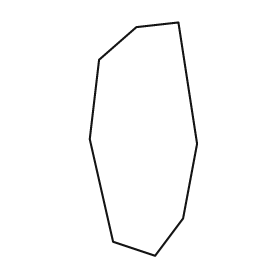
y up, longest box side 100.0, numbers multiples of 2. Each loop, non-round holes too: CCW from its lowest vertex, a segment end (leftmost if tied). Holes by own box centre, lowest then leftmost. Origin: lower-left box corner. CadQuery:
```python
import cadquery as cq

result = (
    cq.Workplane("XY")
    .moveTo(28.0, 0.0)
    .lineTo(40.0, 16.0)
    .lineTo(46.0, 48.0)
    .lineTo(38.0, 100.0)
    .lineTo(20.0, 98.0)
    .lineTo(4.0, 84.0)
    .lineTo(0.0, 50.0)
    .lineTo(10.0, 6.0)
    .close()
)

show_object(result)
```